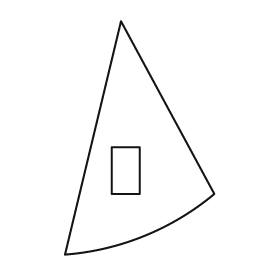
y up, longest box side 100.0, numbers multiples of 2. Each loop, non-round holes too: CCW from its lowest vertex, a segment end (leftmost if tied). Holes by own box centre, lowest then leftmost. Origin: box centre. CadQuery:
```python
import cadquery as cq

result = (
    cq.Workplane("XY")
    .moveTo(-32.0, -50.0)
    .threePointArc((2.0, -42.0), (32.0, -24.0))
    .lineTo(-8.0, 50.0)
    .close()
    .moveTo(-12.0, -24.0)
    .lineTo(0.0, -24.0)
    .lineTo(0.0, -4.0)
    .lineTo(-12.0, -4.0)
    .close()
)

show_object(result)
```